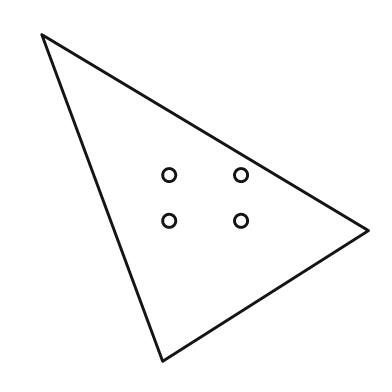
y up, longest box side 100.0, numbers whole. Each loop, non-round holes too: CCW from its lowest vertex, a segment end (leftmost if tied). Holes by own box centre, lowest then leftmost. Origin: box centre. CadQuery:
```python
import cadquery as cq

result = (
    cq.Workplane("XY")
    .moveTo(-13.0, -50.0)
    .lineTo(50.0, -10.0)
    .lineTo(-50.0, 50.0)
    .close()
    .moveTo(-11.0, -7.0)
    .circle(2.0)
    .moveTo(11.0, -7.0)
    .circle(2.0)
    .moveTo(-11.0, 7.0)
    .circle(2.0)
    .moveTo(11.0, 7.0)
    .circle(2.0)
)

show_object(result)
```